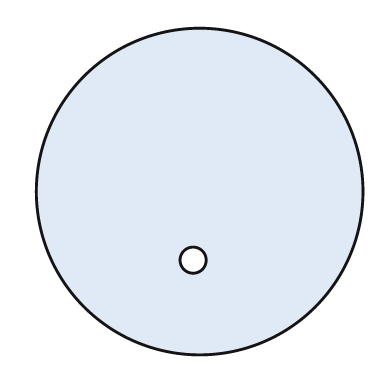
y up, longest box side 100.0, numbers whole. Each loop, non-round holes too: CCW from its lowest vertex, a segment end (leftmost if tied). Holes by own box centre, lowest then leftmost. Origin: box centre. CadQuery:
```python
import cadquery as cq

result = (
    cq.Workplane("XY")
    .moveTo(0.0, 0.0)
    .circle(50.0)
    .moveTo(-2.0, -21.0)
    .circle(4.0)
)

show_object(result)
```